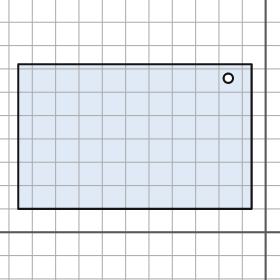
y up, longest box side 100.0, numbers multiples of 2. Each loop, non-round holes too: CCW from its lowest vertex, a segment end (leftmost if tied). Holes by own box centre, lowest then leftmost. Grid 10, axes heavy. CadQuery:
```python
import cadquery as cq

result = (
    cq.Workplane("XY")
    .moveTo(-106.0, 10.0)
    .lineTo(-6.0, 10.0)
    .lineTo(-6.0, 72.0)
    .lineTo(-106.0, 72.0)
    .close()
    .moveTo(-16.0, 66.0)
    .circle(2.0)
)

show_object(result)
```